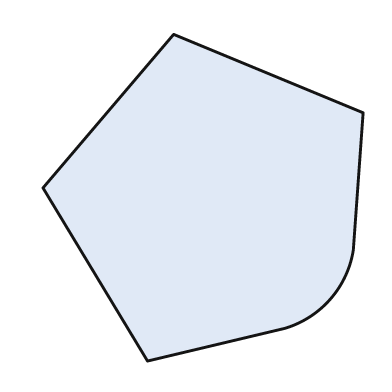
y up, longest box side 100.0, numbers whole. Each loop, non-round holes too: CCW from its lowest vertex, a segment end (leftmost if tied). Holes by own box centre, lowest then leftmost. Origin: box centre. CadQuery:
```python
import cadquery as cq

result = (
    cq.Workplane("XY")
    .moveTo(-17.0, -50.0)
    .lineTo(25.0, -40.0)
    .threePointArc((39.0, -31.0), (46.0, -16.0))
    .lineTo(49.0, 26.0)
    .lineTo(-9.0, 50.0)
    .lineTo(-49.0, 3.0)
    .close()
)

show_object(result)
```